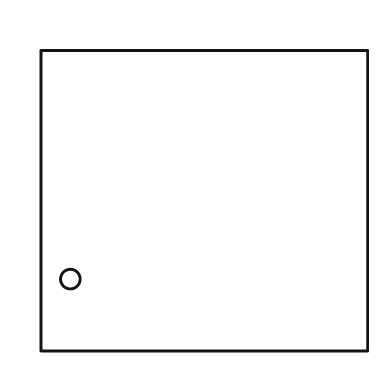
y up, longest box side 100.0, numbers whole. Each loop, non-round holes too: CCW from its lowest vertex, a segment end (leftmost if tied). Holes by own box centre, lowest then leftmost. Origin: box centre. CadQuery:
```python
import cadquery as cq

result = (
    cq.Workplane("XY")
    .moveTo(-50.0, -46.0)
    .lineTo(50.0, -46.0)
    .lineTo(50.0, 46.0)
    .lineTo(-50.0, 46.0)
    .close()
    .moveTo(-41.0, -24.0)
    .circle(3.0)
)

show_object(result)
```